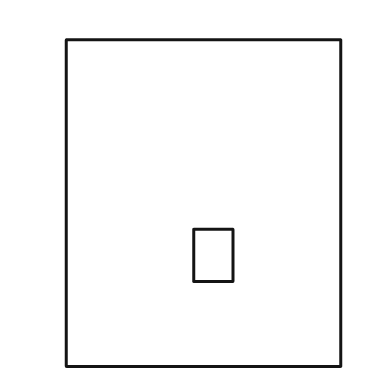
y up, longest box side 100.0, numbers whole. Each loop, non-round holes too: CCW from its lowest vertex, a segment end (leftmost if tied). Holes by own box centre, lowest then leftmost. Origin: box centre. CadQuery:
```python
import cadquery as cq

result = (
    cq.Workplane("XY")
    .moveTo(-42.0, -50.0)
    .lineTo(42.0, -50.0)
    .lineTo(42.0, 50.0)
    .lineTo(-42.0, 50.0)
    .close()
    .moveTo(-3.0, -24.0)
    .lineTo(9.0, -24.0)
    .lineTo(9.0, -8.0)
    .lineTo(-3.0, -8.0)
    .close()
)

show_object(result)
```